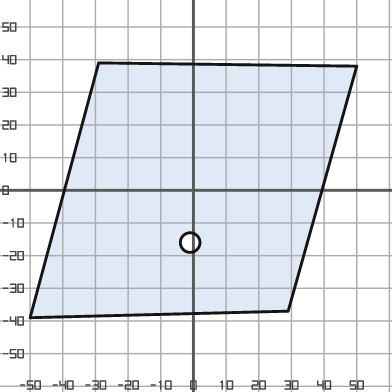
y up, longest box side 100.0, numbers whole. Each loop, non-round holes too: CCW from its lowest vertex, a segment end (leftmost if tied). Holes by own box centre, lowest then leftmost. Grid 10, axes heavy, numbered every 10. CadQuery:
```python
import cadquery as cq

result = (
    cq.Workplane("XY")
    .moveTo(-50.0, -39.0)
    .lineTo(29.0, -37.0)
    .lineTo(50.0, 38.0)
    .lineTo(-29.0, 39.0)
    .close()
    .moveTo(-1.0, -16.0)
    .circle(3.0)
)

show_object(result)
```